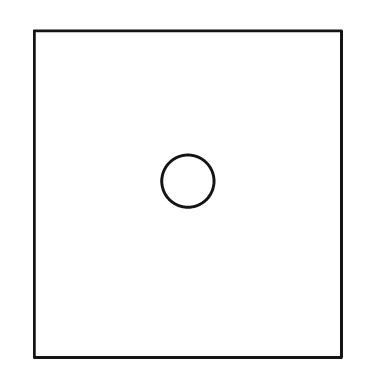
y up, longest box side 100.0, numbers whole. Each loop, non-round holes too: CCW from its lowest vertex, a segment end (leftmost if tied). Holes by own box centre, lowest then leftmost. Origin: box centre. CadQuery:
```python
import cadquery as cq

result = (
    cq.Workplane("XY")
    .moveTo(-47.0, -50.0)
    .lineTo(47.0, -50.0)
    .lineTo(47.0, 50.0)
    .lineTo(-47.0, 50.0)
    .close()
    .moveTo(0.0, 4.0)
    .circle(8.0)
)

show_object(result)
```